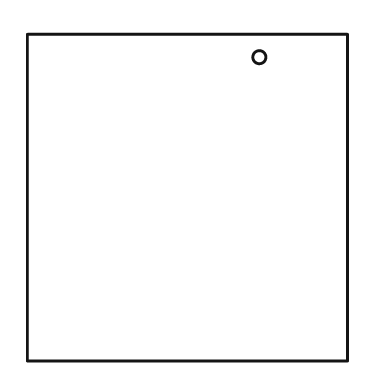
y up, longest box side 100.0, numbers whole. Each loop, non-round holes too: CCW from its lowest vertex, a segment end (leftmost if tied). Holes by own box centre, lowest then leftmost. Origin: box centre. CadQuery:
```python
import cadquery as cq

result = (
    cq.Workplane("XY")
    .moveTo(-49.0, -50.0)
    .lineTo(49.0, -50.0)
    .lineTo(49.0, 50.0)
    .lineTo(-49.0, 50.0)
    .close()
    .moveTo(22.0, 43.0)
    .circle(2.0)
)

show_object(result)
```